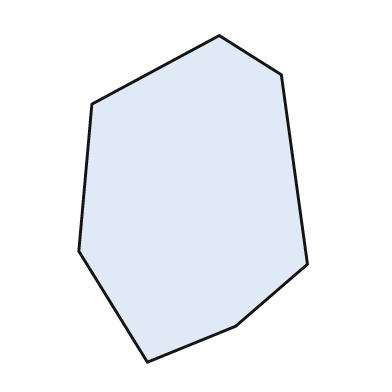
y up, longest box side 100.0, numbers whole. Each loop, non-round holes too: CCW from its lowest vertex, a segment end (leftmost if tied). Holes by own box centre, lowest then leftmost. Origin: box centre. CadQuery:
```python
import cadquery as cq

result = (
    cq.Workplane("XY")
    .moveTo(-14.0, -50.0)
    .lineTo(13.0, -39.0)
    .lineTo(35.0, -20.0)
    .lineTo(27.0, 38.0)
    .lineTo(8.0, 50.0)
    .lineTo(-31.0, 29.0)
    .lineTo(-35.0, -16.0)
    .close()
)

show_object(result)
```